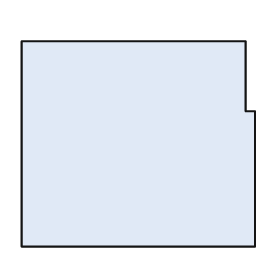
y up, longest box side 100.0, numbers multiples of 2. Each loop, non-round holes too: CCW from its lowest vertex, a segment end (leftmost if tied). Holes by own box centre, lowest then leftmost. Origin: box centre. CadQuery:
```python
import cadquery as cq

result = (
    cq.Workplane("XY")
    .moveTo(-50.0, -44.0)
    .lineTo(50.0, -44.0)
    .lineTo(50.0, 14.0)
    .lineTo(46.0, 14.0)
    .lineTo(46.0, 44.0)
    .lineTo(-50.0, 44.0)
    .close()
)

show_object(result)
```